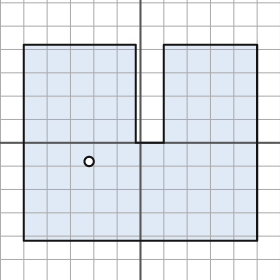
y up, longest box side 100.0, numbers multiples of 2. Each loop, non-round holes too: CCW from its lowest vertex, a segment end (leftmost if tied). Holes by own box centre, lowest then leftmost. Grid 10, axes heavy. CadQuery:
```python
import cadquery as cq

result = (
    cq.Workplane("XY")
    .moveTo(-50.0, -42.0)
    .lineTo(50.0, -42.0)
    .lineTo(50.0, 42.0)
    .lineTo(10.0, 42.0)
    .lineTo(10.0, 0.0)
    .lineTo(-2.0, 0.0)
    .lineTo(-2.0, 42.0)
    .lineTo(-50.0, 42.0)
    .close()
    .moveTo(-22.0, -8.0)
    .circle(2.0)
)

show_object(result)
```